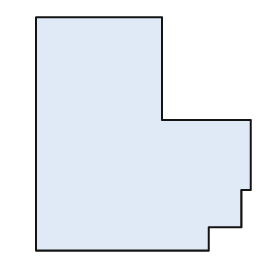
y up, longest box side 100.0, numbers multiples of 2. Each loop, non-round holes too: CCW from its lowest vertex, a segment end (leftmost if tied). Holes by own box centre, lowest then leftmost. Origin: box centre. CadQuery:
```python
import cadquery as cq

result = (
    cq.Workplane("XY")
    .moveTo(-46.0, -50.0)
    .lineTo(28.0, -50.0)
    .lineTo(28.0, -40.0)
    .lineTo(42.0, -40.0)
    .lineTo(42.0, -24.0)
    .lineTo(46.0, -24.0)
    .lineTo(46.0, 6.0)
    .lineTo(8.0, 6.0)
    .lineTo(8.0, 50.0)
    .lineTo(-46.0, 50.0)
    .close()
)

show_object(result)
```